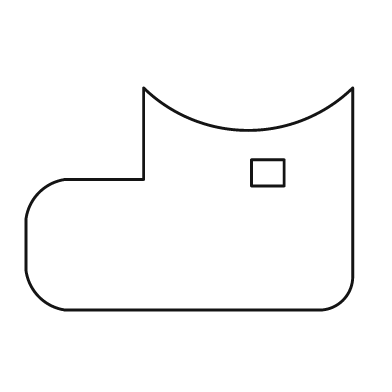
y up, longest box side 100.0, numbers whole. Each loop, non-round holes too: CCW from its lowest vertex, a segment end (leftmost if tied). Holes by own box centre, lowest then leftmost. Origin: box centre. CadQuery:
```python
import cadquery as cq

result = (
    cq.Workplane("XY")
    .moveTo(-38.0, -34.0)
    .lineTo(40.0, -34.0)
    .threePointArc((47.0, -31.0), (50.0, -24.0))
    .lineTo(50.0, 34.0)
    .threePointArc((18.0, 21.0), (-14.0, 34.0))
    .lineTo(-14.0, 6.0)
    .lineTo(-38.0, 6.0)
    .threePointArc((-46.0, 2.0), (-50.0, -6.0))
    .lineTo(-50.0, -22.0)
    .threePointArc((-46.0, -30.0), (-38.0, -34.0))
    .close()
    .moveTo(19.0, 4.0)
    .lineTo(29.0, 4.0)
    .lineTo(29.0, 12.0)
    .lineTo(19.0, 12.0)
    .close()
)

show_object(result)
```